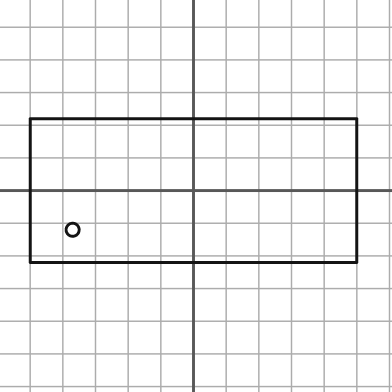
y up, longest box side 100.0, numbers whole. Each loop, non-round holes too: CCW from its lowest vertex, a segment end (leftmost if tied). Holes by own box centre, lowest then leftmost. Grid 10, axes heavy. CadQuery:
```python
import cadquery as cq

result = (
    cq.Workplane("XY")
    .moveTo(-50.0, -22.0)
    .lineTo(50.0, -22.0)
    .lineTo(50.0, 22.0)
    .lineTo(-50.0, 22.0)
    .close()
    .moveTo(-37.0, -12.0)
    .circle(2.0)
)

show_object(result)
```